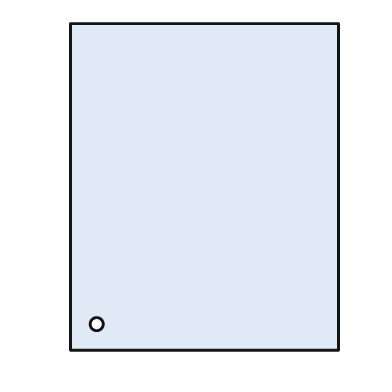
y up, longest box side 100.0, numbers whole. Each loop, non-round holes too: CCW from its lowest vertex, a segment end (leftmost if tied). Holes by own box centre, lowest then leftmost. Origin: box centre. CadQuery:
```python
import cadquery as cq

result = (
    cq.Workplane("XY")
    .moveTo(-41.0, -50.0)
    .lineTo(41.0, -50.0)
    .lineTo(41.0, 50.0)
    .lineTo(-41.0, 50.0)
    .close()
    .moveTo(-33.0, -42.0)
    .circle(2.0)
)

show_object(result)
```